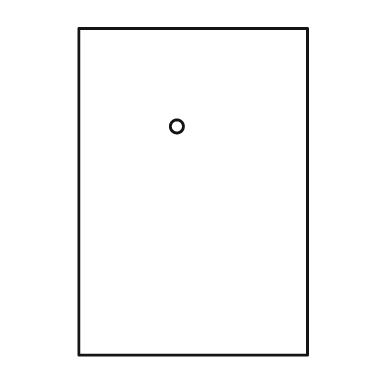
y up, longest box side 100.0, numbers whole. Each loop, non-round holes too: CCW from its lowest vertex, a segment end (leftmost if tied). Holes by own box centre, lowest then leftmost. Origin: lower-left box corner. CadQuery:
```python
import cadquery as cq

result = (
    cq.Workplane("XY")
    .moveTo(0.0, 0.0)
    .lineTo(70.0, 0.0)
    .lineTo(70.0, 100.0)
    .lineTo(0.0, 100.0)
    .close()
    .moveTo(30.0, 70.0)
    .circle(2.0)
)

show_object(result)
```